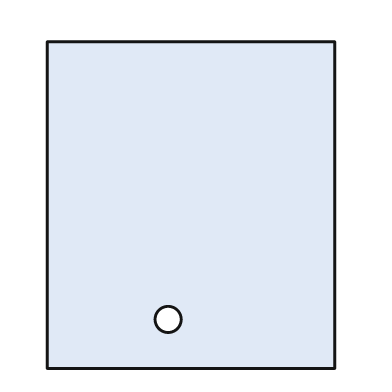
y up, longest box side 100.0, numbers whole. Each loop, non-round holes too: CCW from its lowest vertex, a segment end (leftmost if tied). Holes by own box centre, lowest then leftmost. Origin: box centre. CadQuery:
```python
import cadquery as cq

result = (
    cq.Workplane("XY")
    .moveTo(-44.0, -50.0)
    .lineTo(44.0, -50.0)
    .lineTo(44.0, 50.0)
    .lineTo(-44.0, 50.0)
    .close()
    .moveTo(-7.0, -35.0)
    .circle(4.0)
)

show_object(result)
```